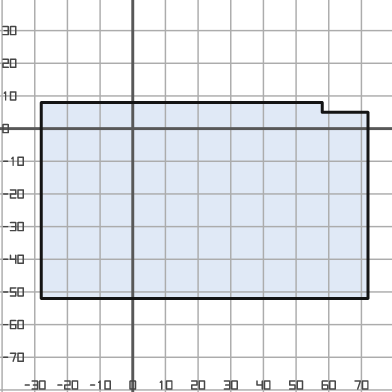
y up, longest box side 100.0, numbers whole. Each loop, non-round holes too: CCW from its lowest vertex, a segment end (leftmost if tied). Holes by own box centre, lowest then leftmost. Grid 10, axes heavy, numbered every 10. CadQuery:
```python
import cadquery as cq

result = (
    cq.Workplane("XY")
    .moveTo(-28.0, -52.0)
    .lineTo(72.0, -52.0)
    .lineTo(72.0, 5.0)
    .lineTo(58.0, 5.0)
    .lineTo(58.0, 8.0)
    .lineTo(-28.0, 8.0)
    .close()
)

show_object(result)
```